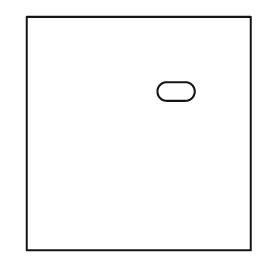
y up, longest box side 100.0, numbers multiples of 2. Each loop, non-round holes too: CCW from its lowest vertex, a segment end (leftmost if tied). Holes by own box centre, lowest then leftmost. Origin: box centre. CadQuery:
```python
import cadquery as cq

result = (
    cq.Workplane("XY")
    .moveTo(-48.0, -50.0)
    .lineTo(48.0, -50.0)
    .lineTo(48.0, 50.0)
    .lineTo(-48.0, 50.0)
    .close()
    .moveTo(12.0, 14.0)
    .lineTo(20.0, 14.0)
    .threePointArc((24.0, 18.0), (20.0, 22.0))
    .lineTo(12.0, 22.0)
    .threePointArc((8.0, 18.0), (12.0, 14.0))
    .close()
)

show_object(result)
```